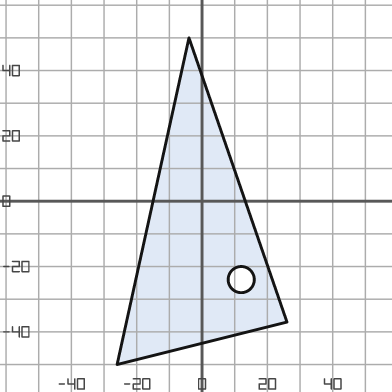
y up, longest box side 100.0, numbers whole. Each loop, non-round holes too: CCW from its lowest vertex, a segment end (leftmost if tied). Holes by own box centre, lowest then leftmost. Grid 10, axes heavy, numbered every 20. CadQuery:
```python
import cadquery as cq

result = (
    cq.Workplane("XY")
    .moveTo(-26.0, -50.0)
    .lineTo(26.0, -37.0)
    .lineTo(-4.0, 50.0)
    .close()
    .moveTo(12.0, -24.0)
    .circle(4.0)
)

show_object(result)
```